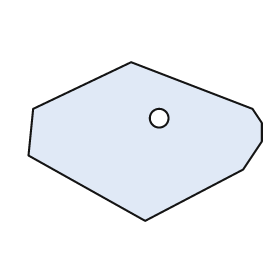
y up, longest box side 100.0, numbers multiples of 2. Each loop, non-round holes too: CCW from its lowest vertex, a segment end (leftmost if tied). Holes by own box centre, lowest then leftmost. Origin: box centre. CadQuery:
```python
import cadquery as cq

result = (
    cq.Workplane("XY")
    .moveTo(0.0, -34.0)
    .lineTo(42.0, -12.0)
    .lineTo(50.0, 0.0)
    .lineTo(50.0, 8.0)
    .lineTo(46.0, 14.0)
    .lineTo(-6.0, 34.0)
    .lineTo(-48.0, 14.0)
    .lineTo(-50.0, -6.0)
    .close()
    .moveTo(6.0, 10.0)
    .circle(4.0)
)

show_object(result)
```